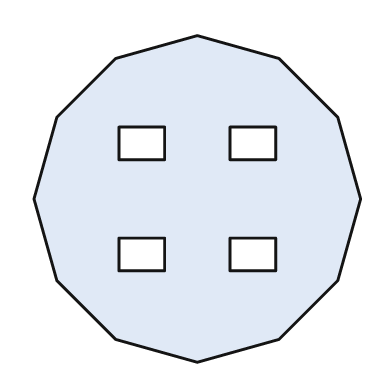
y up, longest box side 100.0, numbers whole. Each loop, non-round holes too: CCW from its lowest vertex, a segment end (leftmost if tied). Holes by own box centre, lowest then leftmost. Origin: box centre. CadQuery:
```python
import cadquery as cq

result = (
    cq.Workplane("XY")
    .moveTo(0.0, -50.0)
    .lineTo(25.0, -43.0)
    .lineTo(43.0, -25.0)
    .lineTo(50.0, 0.0)
    .lineTo(43.0, 25.0)
    .lineTo(25.0, 43.0)
    .lineTo(0.0, 50.0)
    .lineTo(-25.0, 43.0)
    .lineTo(-43.0, 25.0)
    .lineTo(-50.0, 0.0)
    .lineTo(-43.0, -25.0)
    .lineTo(-25.0, -43.0)
    .close()
    .moveTo(-24.0, -22.0)
    .lineTo(-10.0, -22.0)
    .lineTo(-10.0, -12.0)
    .lineTo(-24.0, -12.0)
    .close()
    .moveTo(10.0, -22.0)
    .lineTo(24.0, -22.0)
    .lineTo(24.0, -12.0)
    .lineTo(10.0, -12.0)
    .close()
    .moveTo(-24.0, 12.0)
    .lineTo(-10.0, 12.0)
    .lineTo(-10.0, 22.0)
    .lineTo(-24.0, 22.0)
    .close()
    .moveTo(10.0, 12.0)
    .lineTo(24.0, 12.0)
    .lineTo(24.0, 22.0)
    .lineTo(10.0, 22.0)
    .close()
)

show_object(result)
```